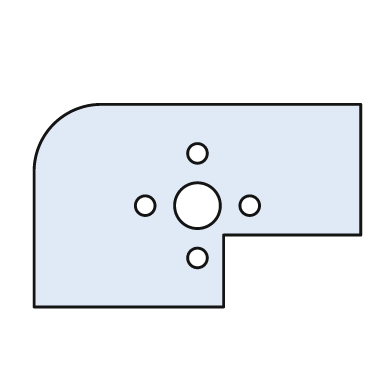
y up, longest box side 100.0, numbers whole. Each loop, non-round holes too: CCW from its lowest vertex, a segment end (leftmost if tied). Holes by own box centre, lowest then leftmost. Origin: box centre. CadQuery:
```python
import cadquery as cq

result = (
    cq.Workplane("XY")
    .moveTo(-50.0, -31.0)
    .lineTo(8.0, -31.0)
    .lineTo(8.0, -9.0)
    .lineTo(50.0, -9.0)
    .lineTo(50.0, 31.0)
    .lineTo(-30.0, 31.0)
    .threePointArc((-44.0, 25.0), (-50.0, 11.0))
    .close()
    .moveTo(0.0, -16.0)
    .circle(3.0)
    .moveTo(-16.0, 0.0)
    .circle(3.0)
    .moveTo(0.0, 0.0)
    .circle(7.0)
    .moveTo(16.0, 0.0)
    .circle(3.0)
    .moveTo(0.0, 16.0)
    .circle(3.0)
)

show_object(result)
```